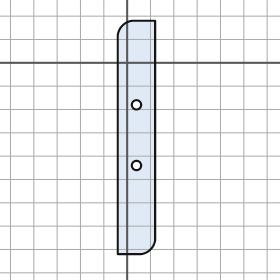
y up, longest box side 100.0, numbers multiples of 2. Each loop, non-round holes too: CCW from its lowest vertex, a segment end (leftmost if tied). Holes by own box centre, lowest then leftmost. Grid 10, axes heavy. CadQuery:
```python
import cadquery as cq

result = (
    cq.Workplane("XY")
    .moveTo(-4.0, -82.0)
    .lineTo(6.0, -82.0)
    .threePointArc((10.0, -80.0), (12.0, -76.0))
    .lineTo(12.0, 18.0)
    .lineTo(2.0, 18.0)
    .threePointArc((-2.0, 16.0), (-4.0, 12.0))
    .close()
    .moveTo(4.0, -44.0)
    .circle(2.0)
    .moveTo(4.0, -18.0)
    .circle(2.0)
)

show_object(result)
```